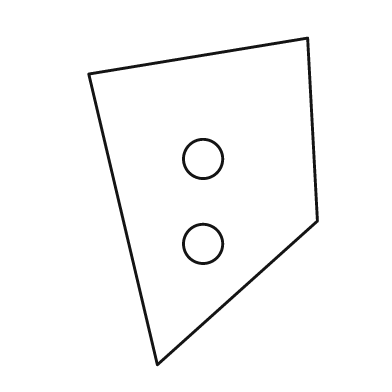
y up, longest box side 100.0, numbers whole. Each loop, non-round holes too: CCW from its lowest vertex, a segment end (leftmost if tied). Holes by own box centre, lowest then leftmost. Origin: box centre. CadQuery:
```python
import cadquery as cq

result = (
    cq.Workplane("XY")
    .moveTo(-14.0, -50.0)
    .lineTo(35.0, -6.0)
    .lineTo(32.0, 50.0)
    .lineTo(-35.0, 39.0)
    .close()
    .moveTo(0.0, -13.0)
    .circle(6.0)
    .moveTo(0.0, 13.0)
    .circle(6.0)
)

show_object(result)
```